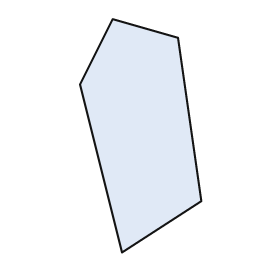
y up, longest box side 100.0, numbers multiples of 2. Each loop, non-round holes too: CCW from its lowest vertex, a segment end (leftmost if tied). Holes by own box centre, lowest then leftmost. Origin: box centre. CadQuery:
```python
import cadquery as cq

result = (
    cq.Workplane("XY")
    .moveTo(-8.0, -50.0)
    .lineTo(26.0, -28.0)
    .lineTo(16.0, 42.0)
    .lineTo(-12.0, 50.0)
    .lineTo(-26.0, 22.0)
    .close()
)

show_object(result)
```